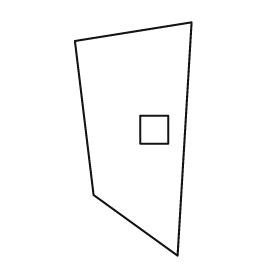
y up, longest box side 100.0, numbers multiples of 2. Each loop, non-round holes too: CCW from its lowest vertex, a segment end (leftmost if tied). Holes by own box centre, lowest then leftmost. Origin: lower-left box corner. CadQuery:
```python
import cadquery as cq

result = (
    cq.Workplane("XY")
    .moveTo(44.0, 0.0)
    .lineTo(50.0, 100.0)
    .lineTo(0.0, 92.0)
    .lineTo(8.0, 26.0)
    .close()
    .moveTo(28.0, 48.0)
    .lineTo(40.0, 48.0)
    .lineTo(40.0, 60.0)
    .lineTo(28.0, 60.0)
    .close()
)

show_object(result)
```